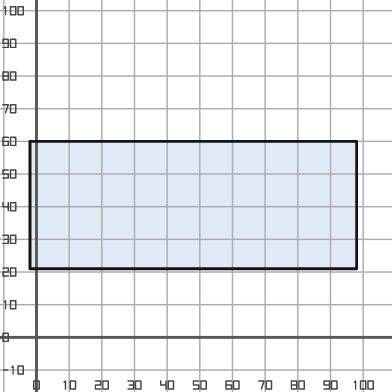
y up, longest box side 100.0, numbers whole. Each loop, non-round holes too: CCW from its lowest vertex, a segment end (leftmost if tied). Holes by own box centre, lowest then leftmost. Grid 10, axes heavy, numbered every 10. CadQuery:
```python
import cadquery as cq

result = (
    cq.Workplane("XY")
    .moveTo(-2.0, 21.0)
    .lineTo(98.0, 21.0)
    .lineTo(98.0, 60.0)
    .lineTo(-2.0, 60.0)
    .close()
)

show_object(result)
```